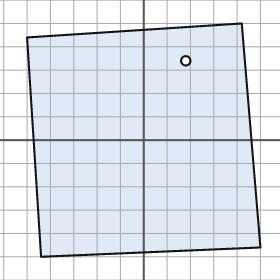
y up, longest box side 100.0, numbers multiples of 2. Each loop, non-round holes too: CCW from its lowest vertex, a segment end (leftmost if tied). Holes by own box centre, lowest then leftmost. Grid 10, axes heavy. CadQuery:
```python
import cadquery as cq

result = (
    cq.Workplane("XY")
    .moveTo(-44.0, -50.0)
    .lineTo(50.0, -46.0)
    .lineTo(42.0, 50.0)
    .lineTo(-50.0, 44.0)
    .close()
    .moveTo(18.0, 34.0)
    .circle(2.0)
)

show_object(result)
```